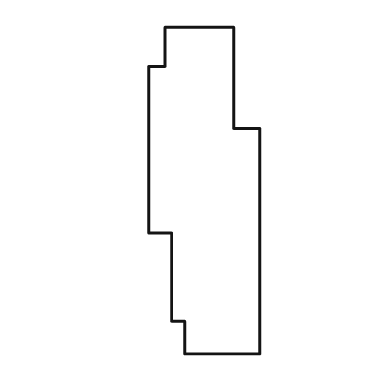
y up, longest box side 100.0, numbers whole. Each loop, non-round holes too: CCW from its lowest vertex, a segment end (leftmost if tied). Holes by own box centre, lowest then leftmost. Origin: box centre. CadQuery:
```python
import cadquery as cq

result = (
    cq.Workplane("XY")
    .moveTo(-6.0, -50.0)
    .lineTo(17.0, -50.0)
    .lineTo(17.0, 19.0)
    .lineTo(9.0, 19.0)
    .lineTo(9.0, 50.0)
    .lineTo(-12.0, 50.0)
    .lineTo(-12.0, 38.0)
    .lineTo(-17.0, 38.0)
    .lineTo(-17.0, -13.0)
    .lineTo(-10.0, -13.0)
    .lineTo(-10.0, -40.0)
    .lineTo(-6.0, -40.0)
    .close()
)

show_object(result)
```